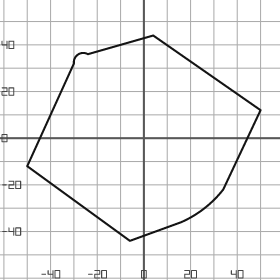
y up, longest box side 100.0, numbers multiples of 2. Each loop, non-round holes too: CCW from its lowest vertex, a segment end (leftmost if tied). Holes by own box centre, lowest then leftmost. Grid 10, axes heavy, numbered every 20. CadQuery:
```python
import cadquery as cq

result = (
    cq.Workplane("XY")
    .moveTo(-6.0, -44.0)
    .lineTo(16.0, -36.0)
    .threePointArc((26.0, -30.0), (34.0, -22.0))
    .lineTo(50.0, 12.0)
    .lineTo(4.0, 44.0)
    .lineTo(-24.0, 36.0)
    .threePointArc((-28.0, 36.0), (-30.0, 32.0))
    .lineTo(-50.0, -12.0)
    .close()
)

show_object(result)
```